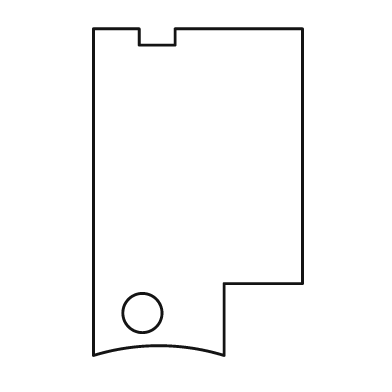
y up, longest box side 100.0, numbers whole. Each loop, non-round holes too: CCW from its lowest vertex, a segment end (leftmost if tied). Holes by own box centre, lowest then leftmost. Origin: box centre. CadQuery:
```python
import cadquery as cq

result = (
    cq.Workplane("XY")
    .moveTo(-32.0, -50.0)
    .threePointArc((-12.0, -47.0), (8.0, -50.0))
    .lineTo(8.0, -28.0)
    .lineTo(32.0, -28.0)
    .lineTo(32.0, 50.0)
    .lineTo(-7.0, 50.0)
    .lineTo(-7.0, 45.0)
    .lineTo(-18.0, 45.0)
    .lineTo(-18.0, 50.0)
    .lineTo(-32.0, 50.0)
    .close()
    .moveTo(-17.0, -37.0)
    .circle(6.0)
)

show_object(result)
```